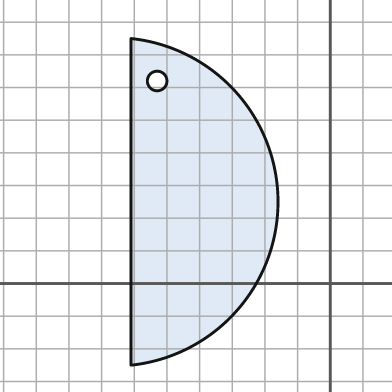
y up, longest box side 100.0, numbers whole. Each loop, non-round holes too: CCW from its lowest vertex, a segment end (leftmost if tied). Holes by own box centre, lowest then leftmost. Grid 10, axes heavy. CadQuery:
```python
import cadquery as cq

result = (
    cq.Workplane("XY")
    .moveTo(-61.0, -25.0)
    .threePointArc((-16.0, 25.0), (-61.0, 75.0))
    .close()
    .moveTo(-53.0, 62.0)
    .circle(3.0)
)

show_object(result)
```